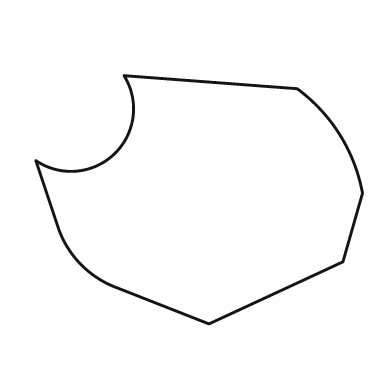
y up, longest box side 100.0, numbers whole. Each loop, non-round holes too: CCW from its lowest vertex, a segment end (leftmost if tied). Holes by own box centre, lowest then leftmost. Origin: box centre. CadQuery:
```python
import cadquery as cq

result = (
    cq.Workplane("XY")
    .moveTo(3.0, -38.0)
    .lineTo(44.0, -19.0)
    .lineTo(50.0, 2.0)
    .threePointArc((43.0, 20.0), (30.0, 34.0))
    .lineTo(-23.0, 38.0)
    .threePointArc((-26.0, 14.0), (-50.0, 12.0))
    .lineTo(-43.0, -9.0)
    .threePointArc((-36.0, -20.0), (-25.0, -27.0))
    .close()
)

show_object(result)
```